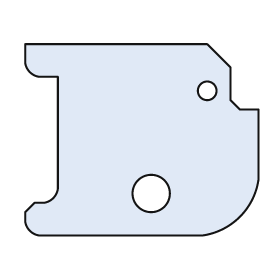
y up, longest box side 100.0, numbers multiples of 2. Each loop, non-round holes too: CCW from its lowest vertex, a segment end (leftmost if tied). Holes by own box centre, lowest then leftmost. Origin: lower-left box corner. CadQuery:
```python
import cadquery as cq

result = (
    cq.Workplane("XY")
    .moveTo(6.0, 0.0)
    .lineTo(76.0, 0.0)
    .threePointArc((92.0, 8.0), (100.0, 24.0))
    .lineTo(100.0, 54.0)
    .lineTo(92.0, 54.0)
    .lineTo(88.0, 58.0)
    .lineTo(88.0, 72.0)
    .lineTo(78.0, 82.0)
    .lineTo(0.0, 82.0)
    .lineTo(0.0, 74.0)
    .threePointArc((2.0, 70.0), (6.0, 68.0))
    .lineTo(14.0, 68.0)
    .lineTo(14.0, 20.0)
    .threePointArc((12.0, 16.0), (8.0, 14.0))
    .lineTo(4.0, 14.0)
    .lineTo(0.0, 10.0)
    .lineTo(0.0, 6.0)
    .threePointArc((2.0, 2.0), (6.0, 0.0))
    .close()
    .moveTo(54.0, 18.0)
    .circle(8.0)
    .moveTo(78.0, 62.0)
    .circle(4.0)
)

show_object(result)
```